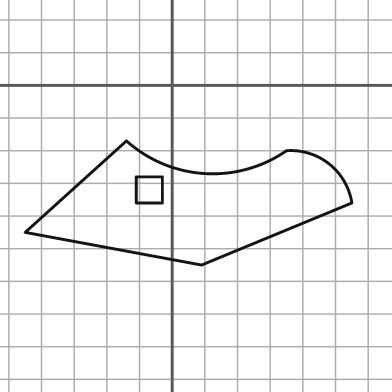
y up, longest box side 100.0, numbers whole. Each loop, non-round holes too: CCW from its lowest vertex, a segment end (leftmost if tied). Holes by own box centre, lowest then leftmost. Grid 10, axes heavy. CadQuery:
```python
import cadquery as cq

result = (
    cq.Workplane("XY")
    .moveTo(9.0, -55.0)
    .lineTo(55.0, -36.0)
    .threePointArc((48.0, -24.0), (35.0, -20.0))
    .threePointArc((10.0, -27.0), (-14.0, -17.0))
    .lineTo(-45.0, -45.0)
    .close()
    .moveTo(-11.0, -36.0)
    .lineTo(-3.0, -36.0)
    .lineTo(-3.0, -28.0)
    .lineTo(-11.0, -28.0)
    .close()
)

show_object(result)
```